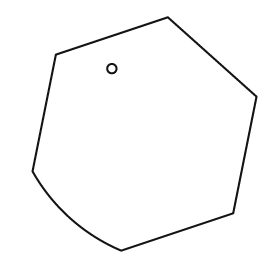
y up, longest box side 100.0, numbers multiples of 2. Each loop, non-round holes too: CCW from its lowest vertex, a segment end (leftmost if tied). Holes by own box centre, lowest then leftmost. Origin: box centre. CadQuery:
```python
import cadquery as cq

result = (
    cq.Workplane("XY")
    .moveTo(-10.0, -50.0)
    .lineTo(38.0, -34.0)
    .lineTo(48.0, 16.0)
    .lineTo(10.0, 50.0)
    .lineTo(-38.0, 34.0)
    .lineTo(-48.0, -16.0)
    .threePointArc((-32.0, -36.0), (-10.0, -50.0))
    .close()
    .moveTo(-14.0, 28.0)
    .circle(2.0)
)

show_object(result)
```